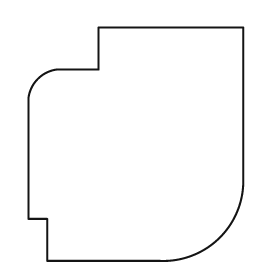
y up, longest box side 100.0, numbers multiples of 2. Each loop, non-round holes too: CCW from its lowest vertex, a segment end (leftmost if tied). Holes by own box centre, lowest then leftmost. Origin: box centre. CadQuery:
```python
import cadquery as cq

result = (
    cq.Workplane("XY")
    .moveTo(-38.0, -50.0)
    .lineTo(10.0, -50.0)
    .threePointArc((36.0, -40.0), (46.0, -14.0))
    .lineTo(46.0, 50.0)
    .lineTo(-16.0, 50.0)
    .lineTo(-16.0, 32.0)
    .lineTo(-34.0, 32.0)
    .threePointArc((-42.0, 28.0), (-46.0, 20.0))
    .lineTo(-46.0, -32.0)
    .lineTo(-38.0, -32.0)
    .close()
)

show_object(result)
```